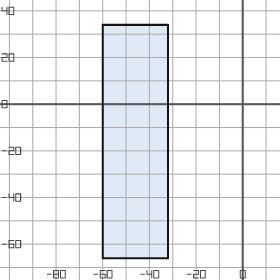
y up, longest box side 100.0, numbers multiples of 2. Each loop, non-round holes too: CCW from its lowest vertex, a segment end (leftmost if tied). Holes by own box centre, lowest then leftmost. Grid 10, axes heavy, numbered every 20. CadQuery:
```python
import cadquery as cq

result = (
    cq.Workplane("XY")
    .moveTo(-60.0, -66.0)
    .lineTo(-32.0, -66.0)
    .lineTo(-32.0, 34.0)
    .lineTo(-60.0, 34.0)
    .close()
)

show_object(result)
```